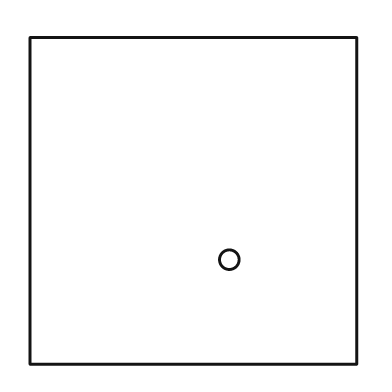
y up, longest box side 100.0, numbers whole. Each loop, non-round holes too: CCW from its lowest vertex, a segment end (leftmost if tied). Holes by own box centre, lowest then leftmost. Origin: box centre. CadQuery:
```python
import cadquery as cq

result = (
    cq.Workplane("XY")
    .moveTo(-50.0, -50.0)
    .lineTo(50.0, -50.0)
    .lineTo(50.0, 50.0)
    .lineTo(-50.0, 50.0)
    .close()
    .moveTo(11.0, -18.0)
    .circle(3.0)
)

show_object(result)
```